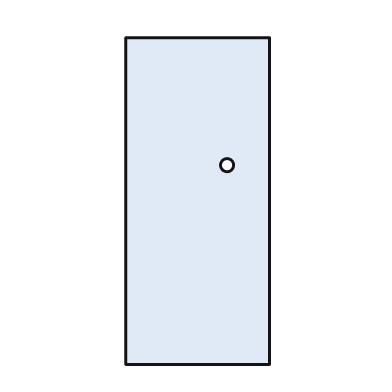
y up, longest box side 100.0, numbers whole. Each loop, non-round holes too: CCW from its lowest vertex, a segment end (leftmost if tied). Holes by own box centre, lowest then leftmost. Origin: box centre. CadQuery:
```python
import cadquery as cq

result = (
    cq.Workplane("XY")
    .moveTo(-22.0, -50.0)
    .lineTo(22.0, -50.0)
    .lineTo(22.0, 50.0)
    .lineTo(-22.0, 50.0)
    .close()
    .moveTo(9.0, 11.0)
    .circle(2.0)
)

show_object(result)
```